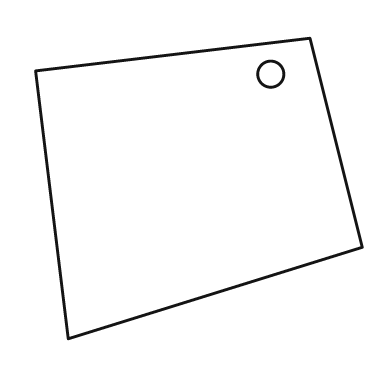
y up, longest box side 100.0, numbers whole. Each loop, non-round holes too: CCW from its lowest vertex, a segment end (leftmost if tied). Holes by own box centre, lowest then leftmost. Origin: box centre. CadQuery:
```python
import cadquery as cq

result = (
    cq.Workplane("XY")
    .moveTo(-40.0, -46.0)
    .lineTo(50.0, -18.0)
    .lineTo(34.0, 46.0)
    .lineTo(-50.0, 36.0)
    .close()
    .moveTo(22.0, 35.0)
    .circle(4.0)
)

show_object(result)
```